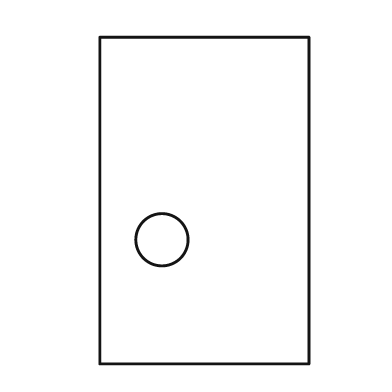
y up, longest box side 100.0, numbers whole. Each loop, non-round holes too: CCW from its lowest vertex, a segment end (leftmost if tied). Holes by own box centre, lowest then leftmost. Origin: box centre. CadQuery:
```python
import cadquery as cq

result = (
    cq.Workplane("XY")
    .moveTo(-32.0, -50.0)
    .lineTo(32.0, -50.0)
    .lineTo(32.0, 50.0)
    .lineTo(-32.0, 50.0)
    .close()
    .moveTo(-13.0, -12.0)
    .circle(8.0)
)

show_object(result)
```